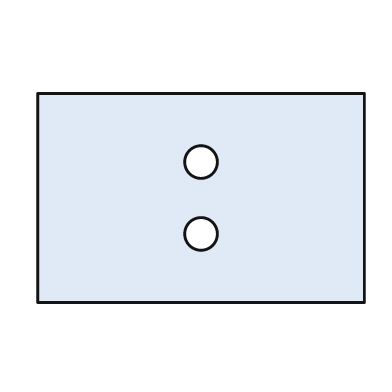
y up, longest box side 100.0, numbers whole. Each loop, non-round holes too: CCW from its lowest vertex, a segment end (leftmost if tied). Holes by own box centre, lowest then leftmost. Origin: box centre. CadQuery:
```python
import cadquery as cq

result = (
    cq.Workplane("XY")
    .moveTo(-50.0, -32.0)
    .lineTo(50.0, -32.0)
    .lineTo(50.0, 32.0)
    .lineTo(-50.0, 32.0)
    .close()
    .moveTo(0.0, -11.0)
    .circle(5.0)
    .moveTo(0.0, 11.0)
    .circle(5.0)
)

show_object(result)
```